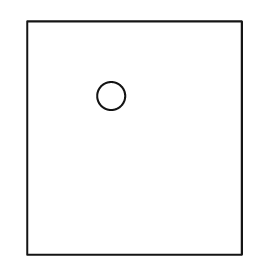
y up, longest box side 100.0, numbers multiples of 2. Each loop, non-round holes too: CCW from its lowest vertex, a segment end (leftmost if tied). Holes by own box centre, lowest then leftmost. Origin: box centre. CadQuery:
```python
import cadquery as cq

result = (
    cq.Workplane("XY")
    .moveTo(-46.0, -50.0)
    .lineTo(46.0, -50.0)
    .lineTo(46.0, 50.0)
    .lineTo(-46.0, 50.0)
    .close()
    .moveTo(-10.0, 18.0)
    .circle(6.0)
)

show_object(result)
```